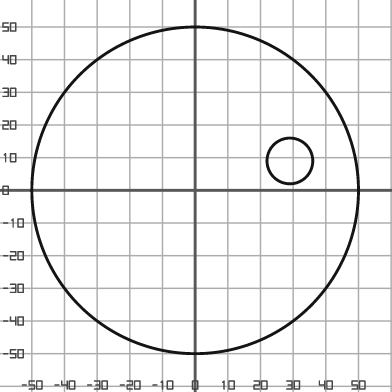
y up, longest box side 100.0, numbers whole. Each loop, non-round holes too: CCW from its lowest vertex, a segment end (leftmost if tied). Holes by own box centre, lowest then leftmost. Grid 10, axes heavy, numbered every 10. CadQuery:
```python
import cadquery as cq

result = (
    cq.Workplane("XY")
    .moveTo(0.0, 0.0)
    .circle(50.0)
    .moveTo(29.0, 9.0)
    .circle(7.0)
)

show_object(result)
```